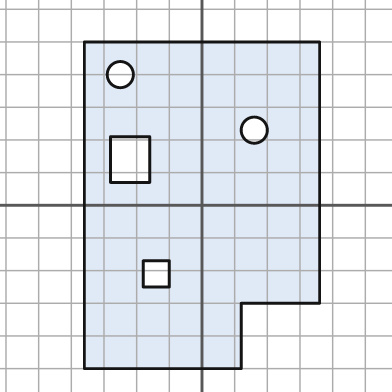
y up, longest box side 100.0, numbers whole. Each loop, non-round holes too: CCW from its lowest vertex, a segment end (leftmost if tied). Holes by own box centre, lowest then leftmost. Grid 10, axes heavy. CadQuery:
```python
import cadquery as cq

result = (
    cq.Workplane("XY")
    .moveTo(-36.0, -50.0)
    .lineTo(12.0, -50.0)
    .lineTo(12.0, -30.0)
    .lineTo(36.0, -30.0)
    .lineTo(36.0, 50.0)
    .lineTo(-36.0, 50.0)
    .close()
    .moveTo(-18.0, -25.0)
    .lineTo(-10.0, -25.0)
    .lineTo(-10.0, -17.0)
    .lineTo(-18.0, -17.0)
    .close()
    .moveTo(-28.0, 7.0)
    .lineTo(-16.0, 7.0)
    .lineTo(-16.0, 21.0)
    .lineTo(-28.0, 21.0)
    .close()
    .moveTo(16.0, 23.0)
    .circle(4.0)
    .moveTo(-25.0, 40.0)
    .circle(4.0)
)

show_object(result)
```